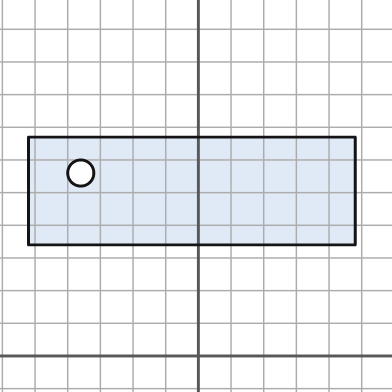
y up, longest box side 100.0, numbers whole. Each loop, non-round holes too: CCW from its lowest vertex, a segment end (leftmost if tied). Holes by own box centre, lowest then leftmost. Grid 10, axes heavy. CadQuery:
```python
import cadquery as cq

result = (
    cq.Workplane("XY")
    .moveTo(-52.0, 34.0)
    .lineTo(48.0, 34.0)
    .lineTo(48.0, 67.0)
    .lineTo(-52.0, 67.0)
    .close()
    .moveTo(-36.0, 56.0)
    .circle(4.0)
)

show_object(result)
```